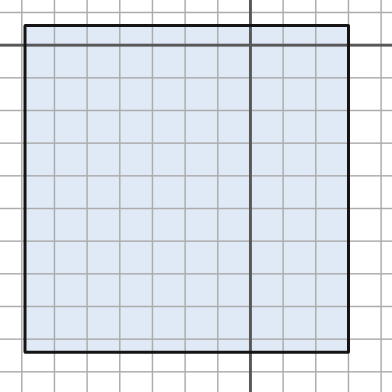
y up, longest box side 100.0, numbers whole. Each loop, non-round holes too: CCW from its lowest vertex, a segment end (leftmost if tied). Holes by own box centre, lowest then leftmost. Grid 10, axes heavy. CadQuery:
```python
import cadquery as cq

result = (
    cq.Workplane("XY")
    .moveTo(-69.0, -94.0)
    .lineTo(30.0, -94.0)
    .lineTo(30.0, 6.0)
    .lineTo(-69.0, 6.0)
    .close()
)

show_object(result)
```